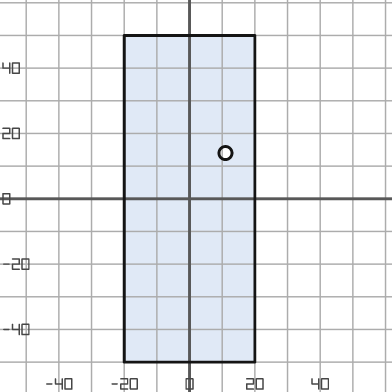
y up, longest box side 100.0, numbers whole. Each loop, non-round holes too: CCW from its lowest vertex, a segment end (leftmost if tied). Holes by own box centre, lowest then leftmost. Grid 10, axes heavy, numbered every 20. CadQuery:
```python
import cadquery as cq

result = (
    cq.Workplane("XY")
    .moveTo(-20.0, -50.0)
    .lineTo(20.0, -50.0)
    .lineTo(20.0, 50.0)
    .lineTo(-20.0, 50.0)
    .close()
    .moveTo(11.0, 14.0)
    .circle(2.0)
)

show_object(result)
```